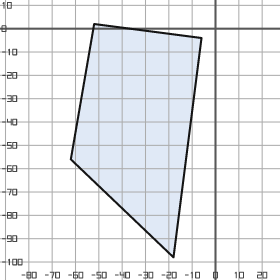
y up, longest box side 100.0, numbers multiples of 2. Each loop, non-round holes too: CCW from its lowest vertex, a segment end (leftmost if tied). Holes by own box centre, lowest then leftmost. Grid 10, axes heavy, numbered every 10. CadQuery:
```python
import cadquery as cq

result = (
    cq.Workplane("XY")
    .moveTo(-18.0, -98.0)
    .lineTo(-6.0, -4.0)
    .lineTo(-52.0, 2.0)
    .lineTo(-62.0, -56.0)
    .close()
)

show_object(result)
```